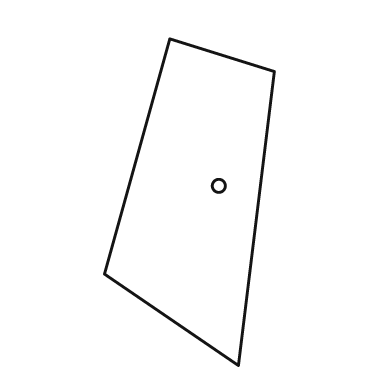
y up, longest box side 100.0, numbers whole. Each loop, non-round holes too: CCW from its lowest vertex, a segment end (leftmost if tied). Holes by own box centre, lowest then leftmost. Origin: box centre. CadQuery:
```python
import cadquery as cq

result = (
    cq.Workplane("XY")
    .moveTo(15.0, -50.0)
    .lineTo(26.0, 40.0)
    .lineTo(-6.0, 50.0)
    .lineTo(-26.0, -22.0)
    .close()
    .moveTo(9.0, 5.0)
    .circle(2.0)
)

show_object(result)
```